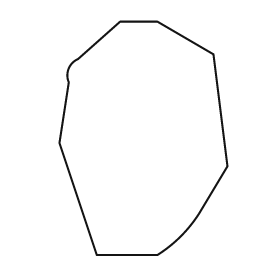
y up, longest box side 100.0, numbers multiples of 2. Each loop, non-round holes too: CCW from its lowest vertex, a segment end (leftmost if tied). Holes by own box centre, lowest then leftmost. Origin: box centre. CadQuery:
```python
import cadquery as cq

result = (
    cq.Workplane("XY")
    .moveTo(-20.0, -50.0)
    .lineTo(6.0, -50.0)
    .threePointArc((16.0, -42.0), (24.0, -32.0))
    .lineTo(36.0, -12.0)
    .lineTo(30.0, 36.0)
    .lineTo(6.0, 50.0)
    .lineTo(-10.0, 50.0)
    .lineTo(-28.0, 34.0)
    .threePointArc((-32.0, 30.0), (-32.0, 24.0))
    .lineTo(-36.0, -2.0)
    .close()
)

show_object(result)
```